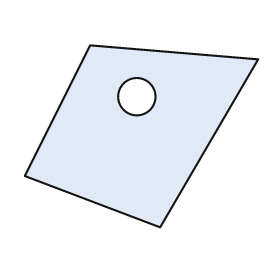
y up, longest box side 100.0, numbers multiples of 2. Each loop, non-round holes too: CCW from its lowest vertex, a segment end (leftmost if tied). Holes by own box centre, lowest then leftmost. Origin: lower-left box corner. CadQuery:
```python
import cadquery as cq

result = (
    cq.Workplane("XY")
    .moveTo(58.0, 0.0)
    .lineTo(100.0, 72.0)
    .lineTo(28.0, 78.0)
    .lineTo(0.0, 22.0)
    .close()
    .moveTo(48.0, 56.0)
    .circle(8.0)
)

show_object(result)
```